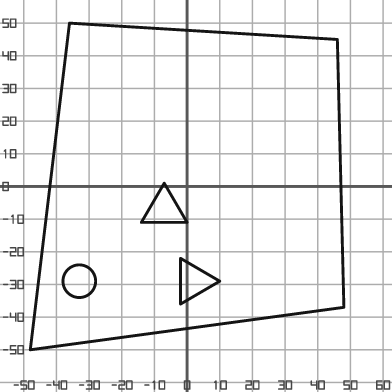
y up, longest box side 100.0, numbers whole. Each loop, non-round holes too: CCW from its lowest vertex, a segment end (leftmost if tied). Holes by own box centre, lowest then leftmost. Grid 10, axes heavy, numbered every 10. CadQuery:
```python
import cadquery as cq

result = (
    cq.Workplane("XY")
    .moveTo(-48.0, -50.0)
    .lineTo(48.0, -37.0)
    .lineTo(46.0, 45.0)
    .lineTo(-36.0, 50.0)
    .close()
    .moveTo(-33.0, -29.0)
    .circle(5.0)
    .moveTo(-2.0, -36.0)
    .lineTo(10.0, -29.0)
    .lineTo(-2.0, -22.0)
    .close()
    .moveTo(-14.0, -11.0)
    .lineTo(0.0, -11.0)
    .lineTo(-7.0, 1.0)
    .close()
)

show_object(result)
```